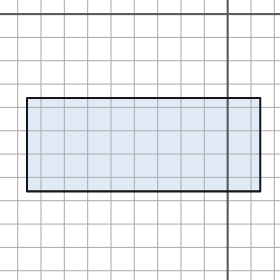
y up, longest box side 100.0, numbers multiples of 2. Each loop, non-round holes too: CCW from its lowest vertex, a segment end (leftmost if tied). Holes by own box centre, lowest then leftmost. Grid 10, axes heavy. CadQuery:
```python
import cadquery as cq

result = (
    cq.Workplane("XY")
    .moveTo(-86.0, -76.0)
    .lineTo(14.0, -76.0)
    .lineTo(14.0, -36.0)
    .lineTo(-86.0, -36.0)
    .close()
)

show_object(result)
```